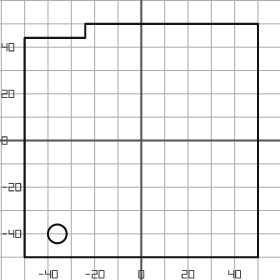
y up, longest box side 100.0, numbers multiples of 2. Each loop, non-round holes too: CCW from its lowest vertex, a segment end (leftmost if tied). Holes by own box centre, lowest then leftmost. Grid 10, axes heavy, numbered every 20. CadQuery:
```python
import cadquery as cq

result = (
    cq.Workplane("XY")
    .moveTo(-50.0, -50.0)
    .lineTo(50.0, -50.0)
    .lineTo(50.0, 50.0)
    .lineTo(-24.0, 50.0)
    .lineTo(-24.0, 44.0)
    .lineTo(-50.0, 44.0)
    .close()
    .moveTo(-36.0, -40.0)
    .circle(4.0)
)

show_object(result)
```